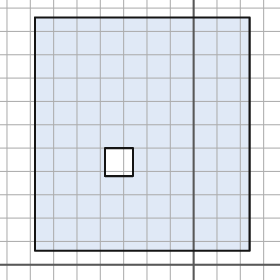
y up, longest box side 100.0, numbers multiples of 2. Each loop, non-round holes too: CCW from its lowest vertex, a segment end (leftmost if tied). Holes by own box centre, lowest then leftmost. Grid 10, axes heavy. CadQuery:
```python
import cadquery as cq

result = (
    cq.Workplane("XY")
    .moveTo(-68.0, 6.0)
    .lineTo(24.0, 6.0)
    .lineTo(24.0, 106.0)
    .lineTo(-68.0, 106.0)
    .close()
    .moveTo(-38.0, 38.0)
    .lineTo(-26.0, 38.0)
    .lineTo(-26.0, 50.0)
    .lineTo(-38.0, 50.0)
    .close()
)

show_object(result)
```